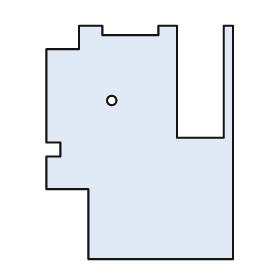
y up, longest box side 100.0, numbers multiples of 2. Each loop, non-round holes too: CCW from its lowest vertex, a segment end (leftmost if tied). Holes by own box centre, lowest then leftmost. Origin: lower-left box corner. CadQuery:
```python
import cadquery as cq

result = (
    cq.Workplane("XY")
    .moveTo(18.0, 0.0)
    .lineTo(80.0, 0.0)
    .lineTo(80.0, 100.0)
    .lineTo(76.0, 100.0)
    .lineTo(76.0, 52.0)
    .lineTo(56.0, 52.0)
    .lineTo(56.0, 100.0)
    .lineTo(48.0, 100.0)
    .lineTo(48.0, 96.0)
    .lineTo(24.0, 96.0)
    .lineTo(24.0, 100.0)
    .lineTo(14.0, 100.0)
    .lineTo(14.0, 90.0)
    .lineTo(0.0, 90.0)
    .lineTo(0.0, 50.0)
    .lineTo(6.0, 50.0)
    .lineTo(6.0, 44.0)
    .lineTo(0.0, 44.0)
    .lineTo(0.0, 30.0)
    .lineTo(18.0, 30.0)
    .close()
    .moveTo(28.0, 68.0)
    .circle(2.0)
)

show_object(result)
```